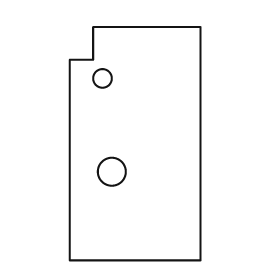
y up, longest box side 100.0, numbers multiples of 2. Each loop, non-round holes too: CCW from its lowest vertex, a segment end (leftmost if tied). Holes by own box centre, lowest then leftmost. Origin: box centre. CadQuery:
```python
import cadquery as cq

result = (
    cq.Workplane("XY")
    .moveTo(-28.0, -50.0)
    .lineTo(28.0, -50.0)
    .lineTo(28.0, 50.0)
    .lineTo(-18.0, 50.0)
    .lineTo(-18.0, 36.0)
    .lineTo(-28.0, 36.0)
    .close()
    .moveTo(-10.0, -12.0)
    .circle(6.0)
    .moveTo(-14.0, 28.0)
    .circle(4.0)
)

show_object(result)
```